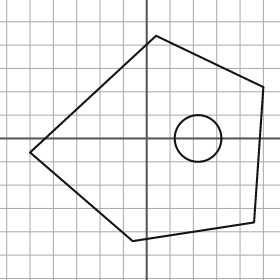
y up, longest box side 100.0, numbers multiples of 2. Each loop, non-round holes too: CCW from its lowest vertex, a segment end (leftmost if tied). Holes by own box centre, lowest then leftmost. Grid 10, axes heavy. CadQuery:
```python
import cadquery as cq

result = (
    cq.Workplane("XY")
    .moveTo(-6.0, -44.0)
    .lineTo(46.0, -36.0)
    .lineTo(50.0, 22.0)
    .lineTo(4.0, 44.0)
    .lineTo(-50.0, -6.0)
    .close()
    .moveTo(22.0, 0.0)
    .circle(10.0)
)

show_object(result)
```